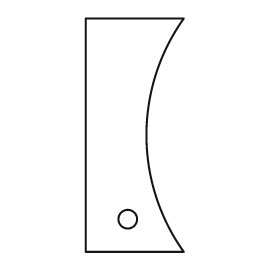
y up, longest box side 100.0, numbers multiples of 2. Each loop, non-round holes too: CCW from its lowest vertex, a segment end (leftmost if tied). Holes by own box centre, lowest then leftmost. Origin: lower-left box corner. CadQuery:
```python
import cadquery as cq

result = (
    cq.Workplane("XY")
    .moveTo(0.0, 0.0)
    .lineTo(42.0, 0.0)
    .threePointArc((26.0, 50.0), (42.0, 100.0))
    .lineTo(0.0, 100.0)
    .close()
    .moveTo(18.0, 14.0)
    .circle(4.0)
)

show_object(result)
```